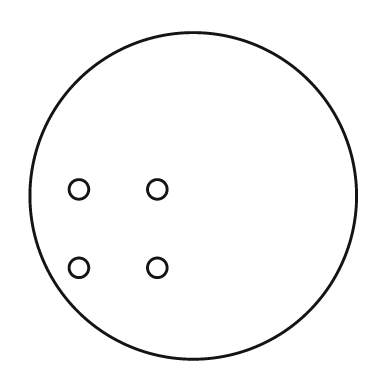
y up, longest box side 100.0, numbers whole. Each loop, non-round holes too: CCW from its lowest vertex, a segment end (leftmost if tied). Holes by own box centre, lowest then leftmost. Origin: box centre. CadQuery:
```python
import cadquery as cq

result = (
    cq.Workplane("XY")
    .moveTo(0.0, 0.0)
    .circle(50.0)
    .moveTo(-35.0, -22.0)
    .circle(3.0)
    .moveTo(-11.0, -22.0)
    .circle(3.0)
    .moveTo(-35.0, 2.0)
    .circle(3.0)
    .moveTo(-11.0, 2.0)
    .circle(3.0)
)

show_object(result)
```